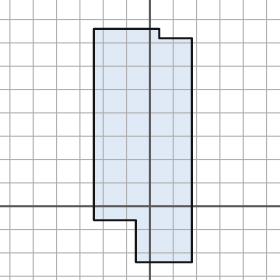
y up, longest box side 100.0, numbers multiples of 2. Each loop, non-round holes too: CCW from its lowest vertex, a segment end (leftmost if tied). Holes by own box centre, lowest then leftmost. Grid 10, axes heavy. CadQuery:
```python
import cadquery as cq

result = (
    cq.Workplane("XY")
    .moveTo(-6.0, -24.0)
    .lineTo(18.0, -24.0)
    .lineTo(18.0, 72.0)
    .lineTo(4.0, 72.0)
    .lineTo(4.0, 76.0)
    .lineTo(-24.0, 76.0)
    .lineTo(-24.0, -6.0)
    .lineTo(-6.0, -6.0)
    .close()
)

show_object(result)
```